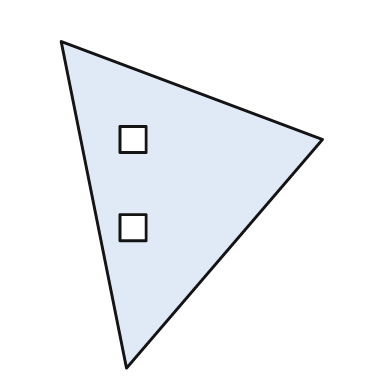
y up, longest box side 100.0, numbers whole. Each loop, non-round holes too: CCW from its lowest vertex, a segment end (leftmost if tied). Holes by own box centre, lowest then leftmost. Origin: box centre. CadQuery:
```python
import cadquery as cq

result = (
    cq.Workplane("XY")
    .moveTo(-20.0, -50.0)
    .lineTo(40.0, 20.0)
    .lineTo(-40.0, 50.0)
    .close()
    .moveTo(-22.0, -11.0)
    .lineTo(-14.0, -11.0)
    .lineTo(-14.0, -3.0)
    .lineTo(-22.0, -3.0)
    .close()
    .moveTo(-22.0, 16.0)
    .lineTo(-14.0, 16.0)
    .lineTo(-14.0, 24.0)
    .lineTo(-22.0, 24.0)
    .close()
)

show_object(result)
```